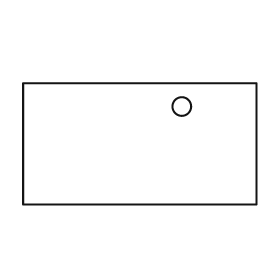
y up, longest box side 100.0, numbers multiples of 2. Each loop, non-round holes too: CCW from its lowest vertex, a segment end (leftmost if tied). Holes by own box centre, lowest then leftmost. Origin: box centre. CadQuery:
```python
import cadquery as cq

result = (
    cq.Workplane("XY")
    .moveTo(-50.0, -26.0)
    .lineTo(50.0, -26.0)
    .lineTo(50.0, 26.0)
    .lineTo(-50.0, 26.0)
    .close()
    .moveTo(18.0, 16.0)
    .circle(4.0)
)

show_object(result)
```